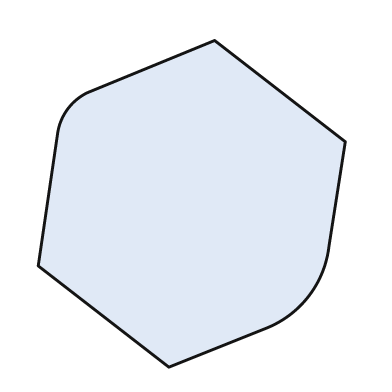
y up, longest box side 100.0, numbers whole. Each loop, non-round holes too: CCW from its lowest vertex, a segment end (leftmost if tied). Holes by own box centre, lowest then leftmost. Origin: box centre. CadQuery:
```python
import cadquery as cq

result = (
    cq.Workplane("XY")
    .moveTo(-7.0, -50.0)
    .lineTo(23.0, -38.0)
    .threePointArc((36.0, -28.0), (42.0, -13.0))
    .lineTo(47.0, 19.0)
    .lineTo(7.0, 50.0)
    .lineTo(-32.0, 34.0)
    .threePointArc((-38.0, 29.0), (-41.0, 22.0))
    .lineTo(-47.0, -19.0)
    .close()
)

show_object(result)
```